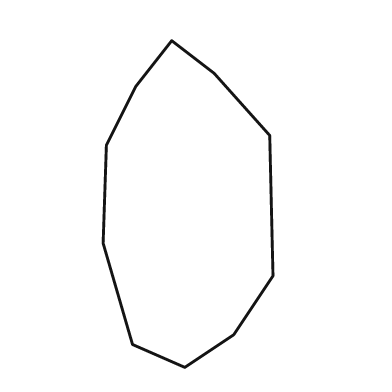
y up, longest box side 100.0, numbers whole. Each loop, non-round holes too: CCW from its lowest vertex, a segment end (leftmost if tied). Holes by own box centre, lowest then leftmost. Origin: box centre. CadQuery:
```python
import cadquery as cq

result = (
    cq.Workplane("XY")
    .moveTo(-1.0, -50.0)
    .lineTo(14.0, -40.0)
    .lineTo(26.0, -22.0)
    .lineTo(25.0, 21.0)
    .lineTo(8.0, 40.0)
    .lineTo(-5.0, 50.0)
    .lineTo(-16.0, 36.0)
    .lineTo(-25.0, 18.0)
    .lineTo(-26.0, -12.0)
    .lineTo(-17.0, -43.0)
    .close()
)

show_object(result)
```